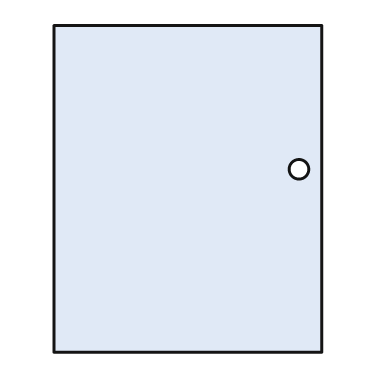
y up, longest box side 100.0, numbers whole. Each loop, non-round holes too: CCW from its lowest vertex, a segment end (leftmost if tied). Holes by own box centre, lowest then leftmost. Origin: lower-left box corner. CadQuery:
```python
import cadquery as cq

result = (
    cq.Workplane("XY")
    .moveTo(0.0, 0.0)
    .lineTo(82.0, 0.0)
    .lineTo(82.0, 100.0)
    .lineTo(0.0, 100.0)
    .close()
    .moveTo(75.0, 56.0)
    .circle(3.0)
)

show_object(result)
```